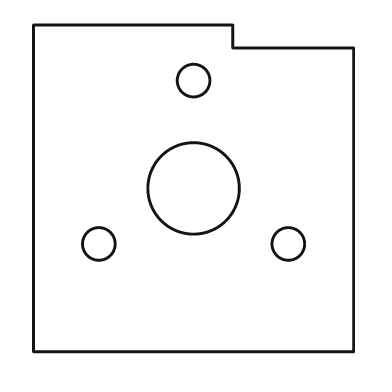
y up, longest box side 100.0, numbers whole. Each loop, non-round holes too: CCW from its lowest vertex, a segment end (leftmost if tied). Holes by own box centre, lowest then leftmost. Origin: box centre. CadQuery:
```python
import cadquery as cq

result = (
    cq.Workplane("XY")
    .moveTo(-49.0, -50.0)
    .lineTo(49.0, -50.0)
    .lineTo(49.0, 43.0)
    .lineTo(12.0, 43.0)
    .lineTo(12.0, 50.0)
    .lineTo(-49.0, 50.0)
    .close()
    .moveTo(-29.0, -17.0)
    .circle(5.0)
    .moveTo(29.0, -17.0)
    .circle(5.0)
    .moveTo(0.0, 0.0)
    .circle(14.0)
    .moveTo(0.0, 33.0)
    .circle(5.0)
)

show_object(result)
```